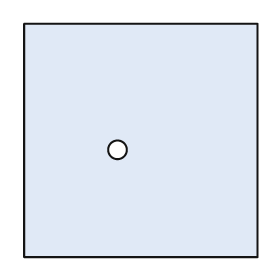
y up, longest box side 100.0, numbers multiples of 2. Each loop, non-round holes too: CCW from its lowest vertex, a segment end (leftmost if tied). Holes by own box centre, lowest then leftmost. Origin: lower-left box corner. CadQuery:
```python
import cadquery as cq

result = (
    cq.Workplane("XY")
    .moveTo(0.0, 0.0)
    .lineTo(100.0, 0.0)
    .lineTo(100.0, 100.0)
    .lineTo(0.0, 100.0)
    .close()
    .moveTo(40.0, 46.0)
    .circle(4.0)
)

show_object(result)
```